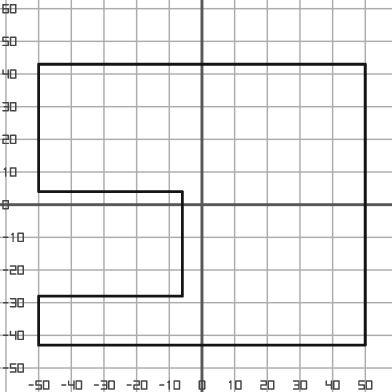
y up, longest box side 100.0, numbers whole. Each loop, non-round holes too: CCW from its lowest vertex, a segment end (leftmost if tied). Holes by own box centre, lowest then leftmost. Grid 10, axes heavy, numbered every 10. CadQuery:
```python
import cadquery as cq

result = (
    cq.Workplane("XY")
    .moveTo(-50.0, -43.0)
    .lineTo(50.0, -43.0)
    .lineTo(50.0, 43.0)
    .lineTo(-50.0, 43.0)
    .lineTo(-50.0, 4.0)
    .lineTo(-6.0, 4.0)
    .lineTo(-6.0, -28.0)
    .lineTo(-50.0, -28.0)
    .close()
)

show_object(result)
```